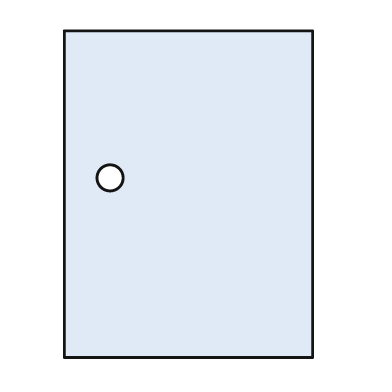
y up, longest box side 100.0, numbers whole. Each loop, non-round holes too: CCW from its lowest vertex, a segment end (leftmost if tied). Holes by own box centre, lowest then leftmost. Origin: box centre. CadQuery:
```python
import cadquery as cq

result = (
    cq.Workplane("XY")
    .moveTo(-38.0, -50.0)
    .lineTo(38.0, -50.0)
    .lineTo(38.0, 50.0)
    .lineTo(-38.0, 50.0)
    .close()
    .moveTo(-24.0, 5.0)
    .circle(4.0)
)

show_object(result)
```